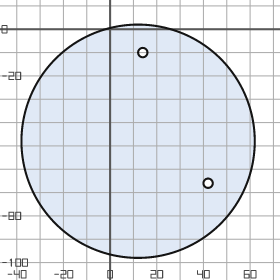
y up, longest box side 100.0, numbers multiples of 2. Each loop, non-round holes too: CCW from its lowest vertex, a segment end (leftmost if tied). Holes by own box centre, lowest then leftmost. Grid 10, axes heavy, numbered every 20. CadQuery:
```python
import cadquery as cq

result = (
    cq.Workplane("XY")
    .moveTo(12.0, -48.0)
    .circle(50.0)
    .moveTo(42.0, -66.0)
    .circle(2.0)
    .moveTo(14.0, -10.0)
    .circle(2.0)
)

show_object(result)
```